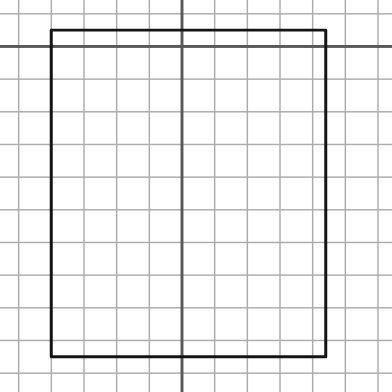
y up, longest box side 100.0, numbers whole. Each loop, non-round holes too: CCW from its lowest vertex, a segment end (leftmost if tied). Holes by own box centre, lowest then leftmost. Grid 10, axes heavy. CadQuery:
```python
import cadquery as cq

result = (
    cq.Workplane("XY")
    .moveTo(-40.0, -95.0)
    .lineTo(44.0, -95.0)
    .lineTo(44.0, 5.0)
    .lineTo(-40.0, 5.0)
    .close()
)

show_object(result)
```